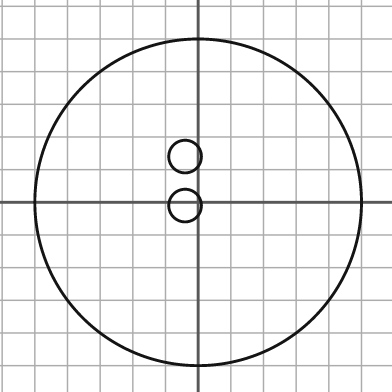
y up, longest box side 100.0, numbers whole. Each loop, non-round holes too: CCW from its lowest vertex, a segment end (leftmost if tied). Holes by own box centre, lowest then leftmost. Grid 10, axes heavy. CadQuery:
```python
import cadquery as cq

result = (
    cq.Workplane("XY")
    .moveTo(0.0, 0.0)
    .circle(50.0)
    .moveTo(-4.0, -1.0)
    .circle(5.0)
    .moveTo(-4.0, 14.0)
    .circle(5.0)
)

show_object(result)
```